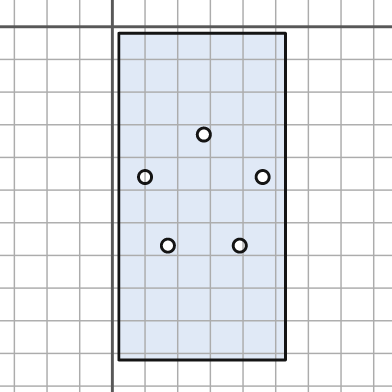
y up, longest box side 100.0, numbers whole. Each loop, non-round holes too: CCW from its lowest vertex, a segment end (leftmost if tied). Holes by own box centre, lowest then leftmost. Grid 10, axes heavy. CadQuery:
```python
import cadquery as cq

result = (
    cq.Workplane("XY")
    .moveTo(2.0, -102.0)
    .lineTo(53.0, -102.0)
    .lineTo(53.0, -2.0)
    .lineTo(2.0, -2.0)
    .close()
    .moveTo(17.0, -67.0)
    .circle(2.0)
    .moveTo(39.0, -67.0)
    .circle(2.0)
    .moveTo(10.0, -46.0)
    .circle(2.0)
    .moveTo(46.0, -46.0)
    .circle(2.0)
    .moveTo(28.0, -33.0)
    .circle(2.0)
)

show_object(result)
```